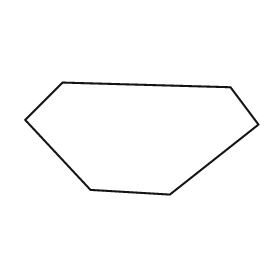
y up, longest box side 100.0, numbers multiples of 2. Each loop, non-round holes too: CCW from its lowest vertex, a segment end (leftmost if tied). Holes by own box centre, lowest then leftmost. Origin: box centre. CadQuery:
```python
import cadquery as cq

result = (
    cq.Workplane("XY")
    .moveTo(12.0, -24.0)
    .lineTo(50.0, 6.0)
    .lineTo(38.0, 22.0)
    .lineTo(-34.0, 24.0)
    .lineTo(-50.0, 8.0)
    .lineTo(-22.0, -22.0)
    .close()
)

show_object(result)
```